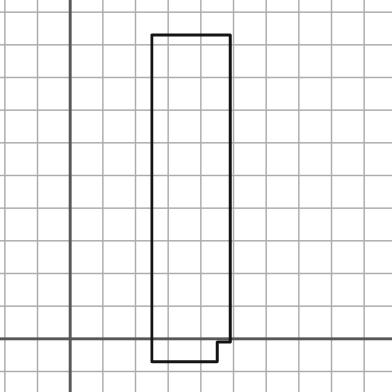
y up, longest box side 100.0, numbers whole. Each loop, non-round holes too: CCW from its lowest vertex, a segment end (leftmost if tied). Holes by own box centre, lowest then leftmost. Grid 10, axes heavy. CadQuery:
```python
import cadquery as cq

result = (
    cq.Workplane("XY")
    .moveTo(25.0, -7.0)
    .lineTo(45.0, -7.0)
    .lineTo(45.0, -1.0)
    .lineTo(49.0, -1.0)
    .lineTo(49.0, 93.0)
    .lineTo(25.0, 93.0)
    .close()
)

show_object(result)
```